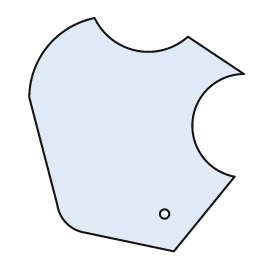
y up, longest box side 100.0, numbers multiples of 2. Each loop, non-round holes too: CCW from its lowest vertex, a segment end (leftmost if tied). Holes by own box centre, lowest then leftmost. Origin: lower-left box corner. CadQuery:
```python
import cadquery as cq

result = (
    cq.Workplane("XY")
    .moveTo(62.0, 0.0)
    .lineTo(88.0, 32.0)
    .threePointArc((70.0, 56.0), (92.0, 76.0))
    .lineTo(68.0, 92.0)
    .threePointArc((46.0, 86.0), (28.0, 100.0))
    .threePointArc((8.0, 88.0), (0.0, 66.0))
    .lineTo(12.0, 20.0)
    .threePointArc((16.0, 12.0), (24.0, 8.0))
    .close()
    .moveTo(58.0, 16.0)
    .circle(2.0)
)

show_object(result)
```